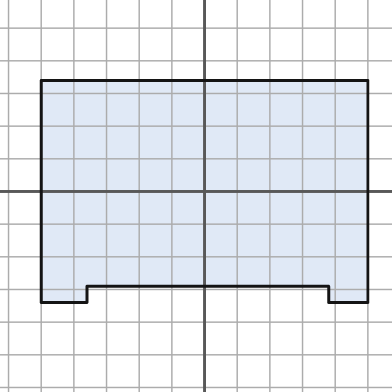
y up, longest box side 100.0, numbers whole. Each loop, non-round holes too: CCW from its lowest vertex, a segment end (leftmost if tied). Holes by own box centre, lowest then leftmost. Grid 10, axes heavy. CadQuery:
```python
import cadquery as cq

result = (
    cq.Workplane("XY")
    .moveTo(-50.0, -34.0)
    .lineTo(-36.0, -34.0)
    .lineTo(-36.0, -29.0)
    .lineTo(38.0, -29.0)
    .lineTo(38.0, -34.0)
    .lineTo(50.0, -34.0)
    .lineTo(50.0, 34.0)
    .lineTo(-50.0, 34.0)
    .close()
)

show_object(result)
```